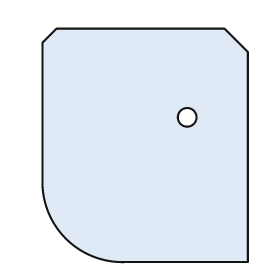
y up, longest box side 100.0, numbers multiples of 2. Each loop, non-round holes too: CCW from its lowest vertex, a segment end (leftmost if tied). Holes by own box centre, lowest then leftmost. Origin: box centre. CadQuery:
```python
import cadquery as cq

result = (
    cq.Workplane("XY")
    .moveTo(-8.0, -50.0)
    .lineTo(44.0, -50.0)
    .lineTo(44.0, 40.0)
    .lineTo(34.0, 50.0)
    .lineTo(-38.0, 50.0)
    .lineTo(-44.0, 44.0)
    .lineTo(-44.0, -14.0)
    .threePointArc((-34.0, -40.0), (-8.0, -50.0))
    .close()
    .moveTo(18.0, 12.0)
    .circle(4.0)
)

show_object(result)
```